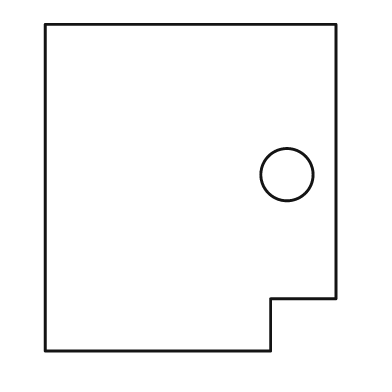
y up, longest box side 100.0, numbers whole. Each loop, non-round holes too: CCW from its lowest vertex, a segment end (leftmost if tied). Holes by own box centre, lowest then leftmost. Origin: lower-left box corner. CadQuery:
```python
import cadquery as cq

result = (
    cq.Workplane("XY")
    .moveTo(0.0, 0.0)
    .lineTo(69.0, 0.0)
    .lineTo(69.0, 16.0)
    .lineTo(89.0, 16.0)
    .lineTo(89.0, 100.0)
    .lineTo(0.0, 100.0)
    .close()
    .moveTo(74.0, 54.0)
    .circle(8.0)
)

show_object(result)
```